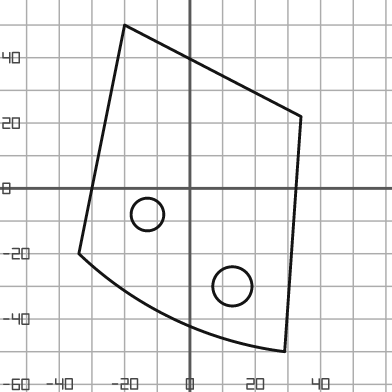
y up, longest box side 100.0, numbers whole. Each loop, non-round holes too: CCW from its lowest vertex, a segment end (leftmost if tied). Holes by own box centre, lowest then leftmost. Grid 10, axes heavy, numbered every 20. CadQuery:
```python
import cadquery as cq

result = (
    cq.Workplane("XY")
    .moveTo(29.0, -50.0)
    .lineTo(34.0, 22.0)
    .lineTo(-20.0, 50.0)
    .lineTo(-34.0, -20.0)
    .threePointArc((-5.0, -40.0), (29.0, -50.0))
    .close()
    .moveTo(13.0, -30.0)
    .circle(6.0)
    .moveTo(-13.0, -8.0)
    .circle(5.0)
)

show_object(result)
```